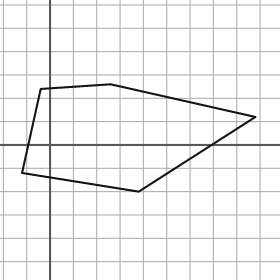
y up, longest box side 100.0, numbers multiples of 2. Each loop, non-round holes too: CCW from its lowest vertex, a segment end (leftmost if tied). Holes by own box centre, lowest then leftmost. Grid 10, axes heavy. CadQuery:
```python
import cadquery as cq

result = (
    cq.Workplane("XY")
    .moveTo(38.0, -20.0)
    .lineTo(88.0, 12.0)
    .lineTo(26.0, 26.0)
    .lineTo(-4.0, 24.0)
    .lineTo(-12.0, -12.0)
    .close()
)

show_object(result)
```